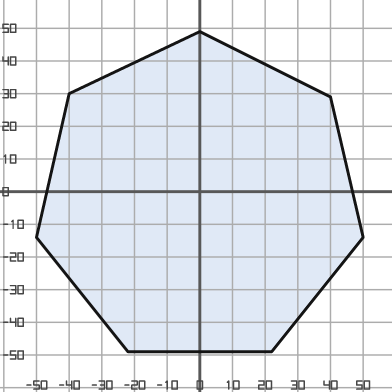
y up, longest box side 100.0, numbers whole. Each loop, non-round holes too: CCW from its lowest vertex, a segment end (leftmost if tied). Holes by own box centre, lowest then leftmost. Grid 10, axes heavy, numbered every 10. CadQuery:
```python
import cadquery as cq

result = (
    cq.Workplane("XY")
    .moveTo(-22.0, -49.0)
    .lineTo(22.0, -49.0)
    .lineTo(50.0, -14.0)
    .lineTo(40.0, 29.0)
    .lineTo(0.0, 49.0)
    .lineTo(-40.0, 30.0)
    .lineTo(-50.0, -14.0)
    .close()
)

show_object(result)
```